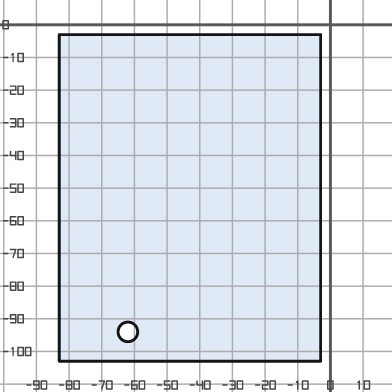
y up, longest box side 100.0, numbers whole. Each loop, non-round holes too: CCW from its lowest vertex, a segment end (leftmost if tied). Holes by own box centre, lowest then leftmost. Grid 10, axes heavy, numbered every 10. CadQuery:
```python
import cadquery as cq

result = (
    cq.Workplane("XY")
    .moveTo(-83.0, -103.0)
    .lineTo(-3.0, -103.0)
    .lineTo(-3.0, -3.0)
    .lineTo(-83.0, -3.0)
    .close()
    .moveTo(-62.0, -94.0)
    .circle(3.0)
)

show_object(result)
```